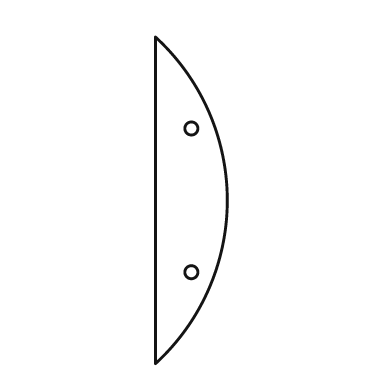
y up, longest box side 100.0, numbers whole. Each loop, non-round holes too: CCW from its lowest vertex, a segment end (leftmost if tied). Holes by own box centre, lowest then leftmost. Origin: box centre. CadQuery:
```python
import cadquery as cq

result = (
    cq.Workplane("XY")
    .moveTo(-11.0, -50.0)
    .threePointArc((11.0, 0.0), (-11.0, 50.0))
    .close()
    .moveTo(0.0, -22.0)
    .circle(2.0)
    .moveTo(0.0, 22.0)
    .circle(2.0)
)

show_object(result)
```